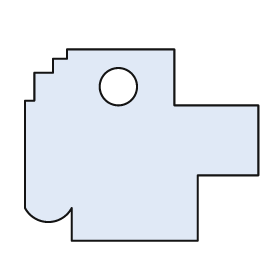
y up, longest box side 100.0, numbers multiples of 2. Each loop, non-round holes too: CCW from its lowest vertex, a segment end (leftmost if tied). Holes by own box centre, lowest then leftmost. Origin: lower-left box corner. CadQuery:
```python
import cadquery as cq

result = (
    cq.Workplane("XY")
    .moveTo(20.0, 0.0)
    .lineTo(74.0, 0.0)
    .lineTo(74.0, 28.0)
    .lineTo(100.0, 28.0)
    .lineTo(100.0, 58.0)
    .lineTo(64.0, 58.0)
    .lineTo(64.0, 82.0)
    .lineTo(18.0, 82.0)
    .lineTo(18.0, 78.0)
    .lineTo(12.0, 78.0)
    .lineTo(12.0, 72.0)
    .lineTo(4.0, 72.0)
    .lineTo(4.0, 60.0)
    .lineTo(0.0, 60.0)
    .lineTo(0.0, 14.0)
    .threePointArc((10.0, 8.0), (20.0, 14.0))
    .close()
    .moveTo(40.0, 66.0)
    .circle(8.0)
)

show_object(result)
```